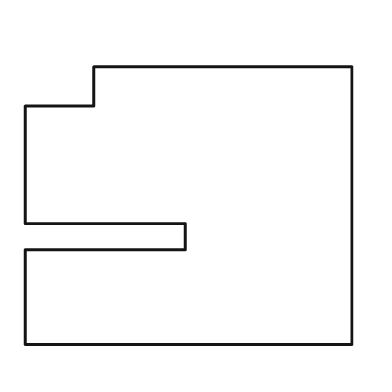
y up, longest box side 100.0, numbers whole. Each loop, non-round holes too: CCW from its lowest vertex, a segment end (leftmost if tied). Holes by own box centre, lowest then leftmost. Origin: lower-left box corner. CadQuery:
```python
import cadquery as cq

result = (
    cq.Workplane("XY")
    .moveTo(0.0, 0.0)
    .lineTo(100.0, 0.0)
    .lineTo(100.0, 85.0)
    .lineTo(21.0, 85.0)
    .lineTo(21.0, 73.0)
    .lineTo(0.0, 73.0)
    .lineTo(0.0, 37.0)
    .lineTo(49.0, 37.0)
    .lineTo(49.0, 29.0)
    .lineTo(0.0, 29.0)
    .close()
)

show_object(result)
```